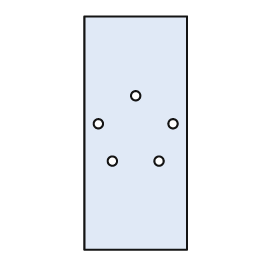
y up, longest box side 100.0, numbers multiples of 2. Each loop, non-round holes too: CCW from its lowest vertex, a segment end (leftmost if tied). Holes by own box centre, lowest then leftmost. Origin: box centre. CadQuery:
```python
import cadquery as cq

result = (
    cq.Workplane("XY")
    .moveTo(-22.0, -50.0)
    .lineTo(22.0, -50.0)
    .lineTo(22.0, 50.0)
    .lineTo(-22.0, 50.0)
    .close()
    .moveTo(-10.0, -12.0)
    .circle(2.0)
    .moveTo(10.0, -12.0)
    .circle(2.0)
    .moveTo(-16.0, 4.0)
    .circle(2.0)
    .moveTo(16.0, 4.0)
    .circle(2.0)
    .moveTo(0.0, 16.0)
    .circle(2.0)
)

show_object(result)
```